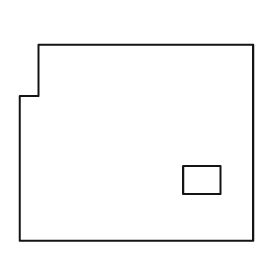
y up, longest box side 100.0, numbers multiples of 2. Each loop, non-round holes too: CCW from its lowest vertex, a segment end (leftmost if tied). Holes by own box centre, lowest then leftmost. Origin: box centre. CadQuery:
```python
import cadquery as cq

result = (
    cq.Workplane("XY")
    .moveTo(-50.0, -42.0)
    .lineTo(50.0, -42.0)
    .lineTo(50.0, 42.0)
    .lineTo(-42.0, 42.0)
    .lineTo(-42.0, 20.0)
    .lineTo(-50.0, 20.0)
    .close()
    .moveTo(20.0, -22.0)
    .lineTo(36.0, -22.0)
    .lineTo(36.0, -10.0)
    .lineTo(20.0, -10.0)
    .close()
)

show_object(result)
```